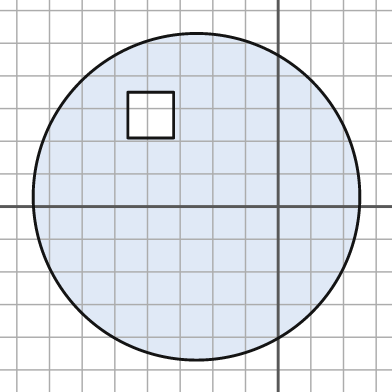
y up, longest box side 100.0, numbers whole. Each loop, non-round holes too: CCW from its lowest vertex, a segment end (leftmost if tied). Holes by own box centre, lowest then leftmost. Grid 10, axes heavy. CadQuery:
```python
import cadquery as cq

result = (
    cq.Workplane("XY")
    .moveTo(-25.0, 3.0)
    .circle(50.0)
    .moveTo(-46.0, 21.0)
    .lineTo(-32.0, 21.0)
    .lineTo(-32.0, 35.0)
    .lineTo(-46.0, 35.0)
    .close()
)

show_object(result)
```